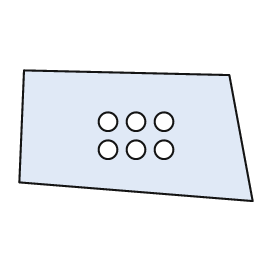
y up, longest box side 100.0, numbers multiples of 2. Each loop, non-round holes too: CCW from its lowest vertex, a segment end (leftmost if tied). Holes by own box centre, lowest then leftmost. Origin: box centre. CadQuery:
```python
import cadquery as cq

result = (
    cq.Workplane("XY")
    .moveTo(50.0, -28.0)
    .lineTo(40.0, 26.0)
    .lineTo(-48.0, 28.0)
    .lineTo(-50.0, -20.0)
    .close()
    .moveTo(-12.0, -6.0)
    .circle(4.0)
    .moveTo(0.0, -6.0)
    .circle(4.0)
    .moveTo(12.0, -6.0)
    .circle(4.0)
    .moveTo(-12.0, 6.0)
    .circle(4.0)
    .moveTo(0.0, 6.0)
    .circle(4.0)
    .moveTo(12.0, 6.0)
    .circle(4.0)
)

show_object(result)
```